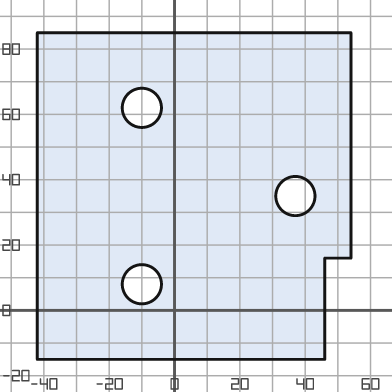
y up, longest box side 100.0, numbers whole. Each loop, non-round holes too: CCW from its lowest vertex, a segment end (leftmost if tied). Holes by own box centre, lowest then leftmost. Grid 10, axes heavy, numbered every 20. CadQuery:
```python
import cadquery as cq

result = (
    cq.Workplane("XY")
    .moveTo(-42.0, -15.0)
    .lineTo(46.0, -15.0)
    .lineTo(46.0, 16.0)
    .lineTo(54.0, 16.0)
    .lineTo(54.0, 85.0)
    .lineTo(-42.0, 85.0)
    .close()
    .moveTo(-10.0, 8.0)
    .circle(6.0)
    .moveTo(37.0, 35.0)
    .circle(6.0)
    .moveTo(-10.0, 62.0)
    .circle(6.0)
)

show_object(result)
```